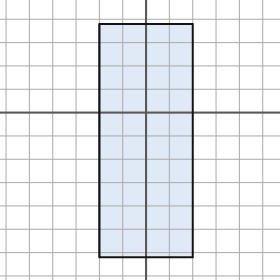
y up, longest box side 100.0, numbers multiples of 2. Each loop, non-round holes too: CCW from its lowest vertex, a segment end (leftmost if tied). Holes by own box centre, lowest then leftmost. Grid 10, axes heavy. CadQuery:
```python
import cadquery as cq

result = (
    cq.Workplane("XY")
    .moveTo(-20.0, -62.0)
    .lineTo(20.0, -62.0)
    .lineTo(20.0, 38.0)
    .lineTo(-20.0, 38.0)
    .close()
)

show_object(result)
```